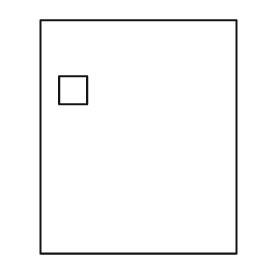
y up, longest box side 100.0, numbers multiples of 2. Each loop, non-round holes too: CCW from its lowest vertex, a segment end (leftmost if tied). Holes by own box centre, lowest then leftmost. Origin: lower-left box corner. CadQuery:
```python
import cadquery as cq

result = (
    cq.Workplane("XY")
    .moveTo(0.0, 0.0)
    .lineTo(84.0, 0.0)
    .lineTo(84.0, 100.0)
    .lineTo(0.0, 100.0)
    .close()
    .moveTo(8.0, 64.0)
    .lineTo(20.0, 64.0)
    .lineTo(20.0, 76.0)
    .lineTo(8.0, 76.0)
    .close()
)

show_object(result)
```